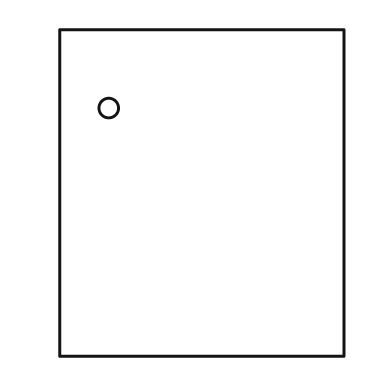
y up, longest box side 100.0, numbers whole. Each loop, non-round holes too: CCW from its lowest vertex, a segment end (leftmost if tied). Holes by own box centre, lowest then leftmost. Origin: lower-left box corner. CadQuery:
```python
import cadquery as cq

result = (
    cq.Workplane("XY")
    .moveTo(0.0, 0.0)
    .lineTo(87.0, 0.0)
    .lineTo(87.0, 100.0)
    .lineTo(0.0, 100.0)
    .close()
    .moveTo(15.0, 76.0)
    .circle(3.0)
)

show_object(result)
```